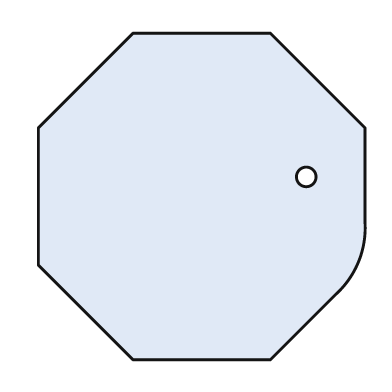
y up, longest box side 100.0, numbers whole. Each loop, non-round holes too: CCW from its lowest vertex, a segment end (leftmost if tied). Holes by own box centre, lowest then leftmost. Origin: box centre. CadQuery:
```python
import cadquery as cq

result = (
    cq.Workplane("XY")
    .moveTo(-21.0, -50.0)
    .lineTo(21.0, -50.0)
    .lineTo(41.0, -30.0)
    .threePointArc((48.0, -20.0), (50.0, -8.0))
    .lineTo(50.0, 21.0)
    .lineTo(21.0, 50.0)
    .lineTo(-21.0, 50.0)
    .lineTo(-50.0, 21.0)
    .lineTo(-50.0, -21.0)
    .close()
    .moveTo(32.0, 6.0)
    .circle(3.0)
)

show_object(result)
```